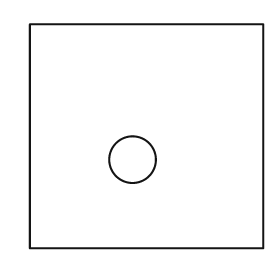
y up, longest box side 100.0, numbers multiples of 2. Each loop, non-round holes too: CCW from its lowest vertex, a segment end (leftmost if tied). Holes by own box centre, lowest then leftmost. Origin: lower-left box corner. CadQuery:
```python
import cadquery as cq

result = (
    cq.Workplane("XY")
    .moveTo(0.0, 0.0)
    .lineTo(100.0, 0.0)
    .lineTo(100.0, 96.0)
    .lineTo(0.0, 96.0)
    .close()
    .moveTo(44.0, 38.0)
    .circle(10.0)
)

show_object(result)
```